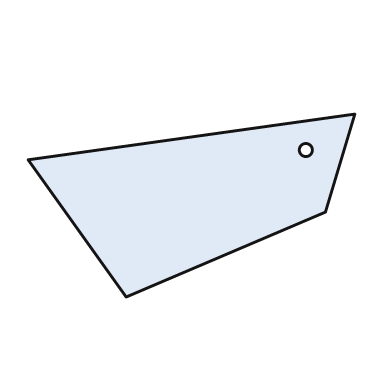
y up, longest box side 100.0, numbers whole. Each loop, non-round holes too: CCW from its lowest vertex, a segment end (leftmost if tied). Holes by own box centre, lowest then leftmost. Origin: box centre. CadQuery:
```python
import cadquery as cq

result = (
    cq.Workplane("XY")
    .moveTo(-20.0, -28.0)
    .lineTo(41.0, -2.0)
    .lineTo(50.0, 28.0)
    .lineTo(-50.0, 14.0)
    .close()
    .moveTo(35.0, 17.0)
    .circle(2.0)
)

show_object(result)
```